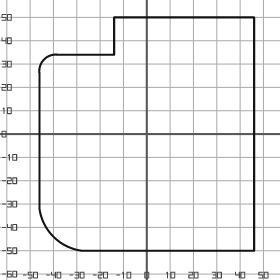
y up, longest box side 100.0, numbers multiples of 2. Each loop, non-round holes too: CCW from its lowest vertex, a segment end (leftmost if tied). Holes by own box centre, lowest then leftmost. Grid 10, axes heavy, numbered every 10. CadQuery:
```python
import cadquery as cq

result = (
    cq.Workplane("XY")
    .moveTo(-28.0, -50.0)
    .lineTo(46.0, -50.0)
    .lineTo(46.0, 50.0)
    .lineTo(-14.0, 50.0)
    .lineTo(-14.0, 34.0)
    .lineTo(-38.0, 34.0)
    .threePointArc((-44.0, 32.0), (-46.0, 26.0))
    .lineTo(-46.0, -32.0)
    .threePointArc((-40.0, -44.0), (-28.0, -50.0))
    .close()
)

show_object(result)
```